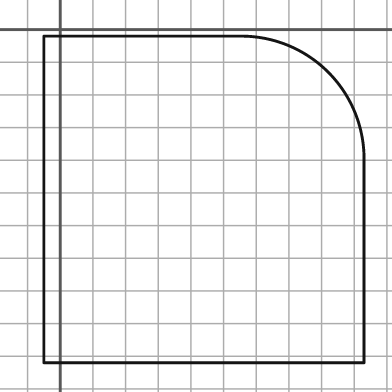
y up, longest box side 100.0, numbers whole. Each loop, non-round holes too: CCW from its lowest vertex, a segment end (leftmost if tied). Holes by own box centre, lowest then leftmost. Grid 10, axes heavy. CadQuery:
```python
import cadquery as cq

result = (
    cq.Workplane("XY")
    .moveTo(-5.0, -102.0)
    .lineTo(93.0, -102.0)
    .lineTo(93.0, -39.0)
    .threePointArc((82.0, -13.0), (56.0, -2.0))
    .lineTo(-5.0, -2.0)
    .close()
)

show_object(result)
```